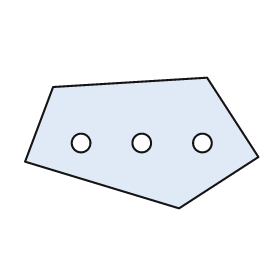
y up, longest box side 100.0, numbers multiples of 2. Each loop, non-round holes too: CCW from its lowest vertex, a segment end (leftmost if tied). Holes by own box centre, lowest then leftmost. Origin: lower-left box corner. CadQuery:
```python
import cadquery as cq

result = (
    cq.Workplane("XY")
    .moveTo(66.0, 0.0)
    .lineTo(100.0, 22.0)
    .lineTo(78.0, 56.0)
    .lineTo(12.0, 52.0)
    .lineTo(0.0, 20.0)
    .close()
    .moveTo(24.0, 28.0)
    .circle(4.0)
    .moveTo(50.0, 28.0)
    .circle(4.0)
    .moveTo(76.0, 28.0)
    .circle(4.0)
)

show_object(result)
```